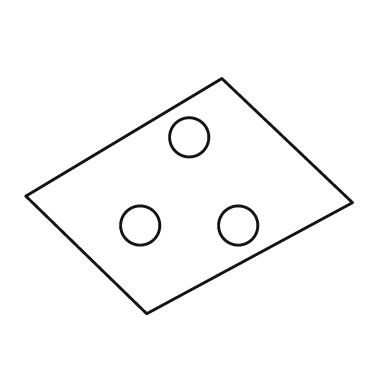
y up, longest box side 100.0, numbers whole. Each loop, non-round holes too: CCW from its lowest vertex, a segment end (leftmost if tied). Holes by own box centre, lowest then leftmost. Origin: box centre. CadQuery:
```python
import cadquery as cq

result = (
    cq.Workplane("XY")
    .moveTo(-13.0, -36.0)
    .lineTo(50.0, -2.0)
    .lineTo(10.0, 36.0)
    .lineTo(-50.0, 0.0)
    .close()
    .moveTo(-15.0, -9.0)
    .circle(6.0)
    .moveTo(15.0, -9.0)
    .circle(6.0)
    .moveTo(0.0, 18.0)
    .circle(6.0)
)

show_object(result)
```